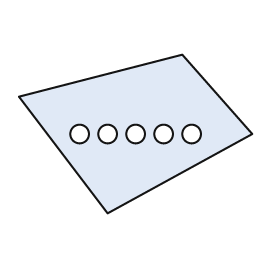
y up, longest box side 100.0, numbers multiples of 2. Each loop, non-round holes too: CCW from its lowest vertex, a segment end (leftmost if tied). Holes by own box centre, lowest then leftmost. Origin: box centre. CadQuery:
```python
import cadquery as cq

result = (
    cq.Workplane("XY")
    .moveTo(-12.0, -34.0)
    .lineTo(50.0, 0.0)
    .lineTo(20.0, 34.0)
    .lineTo(-50.0, 16.0)
    .close()
    .moveTo(-24.0, 0.0)
    .circle(4.0)
    .moveTo(-12.0, 0.0)
    .circle(4.0)
    .moveTo(0.0, 0.0)
    .circle(4.0)
    .moveTo(12.0, 0.0)
    .circle(4.0)
    .moveTo(24.0, 0.0)
    .circle(4.0)
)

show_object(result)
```